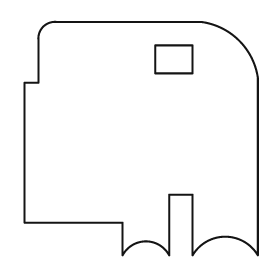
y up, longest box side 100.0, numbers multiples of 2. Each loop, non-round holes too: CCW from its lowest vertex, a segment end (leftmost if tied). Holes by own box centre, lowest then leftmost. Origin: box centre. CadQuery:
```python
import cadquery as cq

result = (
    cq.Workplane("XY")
    .moveTo(-8.0, -50.0)
    .threePointArc((2.0, -44.0), (12.0, -50.0))
    .lineTo(12.0, -24.0)
    .lineTo(22.0, -24.0)
    .lineTo(22.0, -50.0)
    .threePointArc((36.0, -42.0), (50.0, -50.0))
    .lineTo(50.0, 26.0)
    .threePointArc((42.0, 42.0), (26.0, 50.0))
    .lineTo(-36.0, 50.0)
    .threePointArc((-42.0, 48.0), (-44.0, 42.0))
    .lineTo(-44.0, 24.0)
    .lineTo(-50.0, 24.0)
    .lineTo(-50.0, -36.0)
    .lineTo(-8.0, -36.0)
    .close()
    .moveTo(6.0, 28.0)
    .lineTo(22.0, 28.0)
    .lineTo(22.0, 40.0)
    .lineTo(6.0, 40.0)
    .close()
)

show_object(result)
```